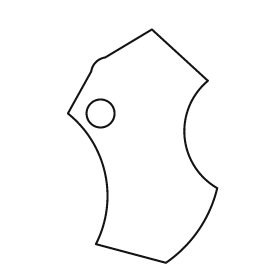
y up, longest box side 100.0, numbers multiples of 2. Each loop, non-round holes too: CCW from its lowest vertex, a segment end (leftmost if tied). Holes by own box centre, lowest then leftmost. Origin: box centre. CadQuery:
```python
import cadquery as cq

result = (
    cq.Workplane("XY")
    .moveTo(10.0, -50.0)
    .threePointArc((24.0, -36.0), (32.0, -18.0))
    .threePointArc((18.0, 4.0), (28.0, 28.0))
    .lineTo(4.0, 50.0)
    .lineTo(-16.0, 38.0)
    .threePointArc((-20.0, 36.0), (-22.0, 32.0))
    .lineTo(-32.0, 14.0)
    .threePointArc((-16.0, -12.0), (-20.0, -42.0))
    .close()
    .moveTo(-18.0, 14.0)
    .circle(6.0)
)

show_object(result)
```